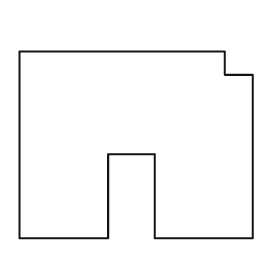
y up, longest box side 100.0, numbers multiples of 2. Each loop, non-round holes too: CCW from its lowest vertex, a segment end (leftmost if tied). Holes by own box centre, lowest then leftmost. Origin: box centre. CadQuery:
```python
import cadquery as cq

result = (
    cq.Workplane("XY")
    .moveTo(-50.0, -40.0)
    .lineTo(-12.0, -40.0)
    .lineTo(-12.0, -4.0)
    .lineTo(8.0, -4.0)
    .lineTo(8.0, -40.0)
    .lineTo(50.0, -40.0)
    .lineTo(50.0, 30.0)
    .lineTo(38.0, 30.0)
    .lineTo(38.0, 40.0)
    .lineTo(-50.0, 40.0)
    .close()
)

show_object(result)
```